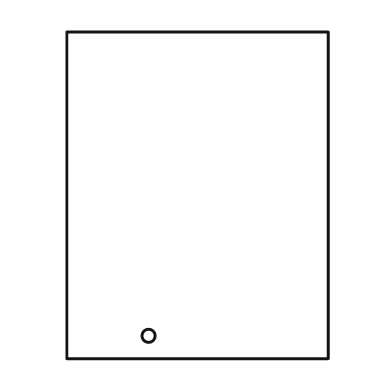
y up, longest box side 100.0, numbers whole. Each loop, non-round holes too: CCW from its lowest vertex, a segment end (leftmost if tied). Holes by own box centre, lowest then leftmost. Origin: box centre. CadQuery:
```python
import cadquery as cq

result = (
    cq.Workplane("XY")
    .moveTo(-40.0, -50.0)
    .lineTo(40.0, -50.0)
    .lineTo(40.0, 50.0)
    .lineTo(-40.0, 50.0)
    .close()
    .moveTo(-15.0, -43.0)
    .circle(2.0)
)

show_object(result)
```